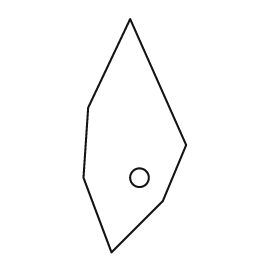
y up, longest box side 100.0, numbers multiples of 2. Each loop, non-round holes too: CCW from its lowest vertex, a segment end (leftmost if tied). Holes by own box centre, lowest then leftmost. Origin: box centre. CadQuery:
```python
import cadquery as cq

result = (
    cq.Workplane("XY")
    .moveTo(-10.0, -50.0)
    .lineTo(12.0, -28.0)
    .lineTo(22.0, -4.0)
    .lineTo(-2.0, 50.0)
    .lineTo(-20.0, 12.0)
    .lineTo(-22.0, -18.0)
    .close()
    .moveTo(2.0, -18.0)
    .circle(4.0)
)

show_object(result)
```